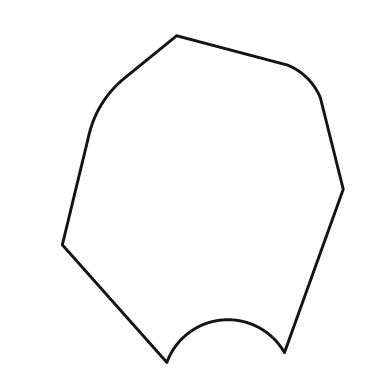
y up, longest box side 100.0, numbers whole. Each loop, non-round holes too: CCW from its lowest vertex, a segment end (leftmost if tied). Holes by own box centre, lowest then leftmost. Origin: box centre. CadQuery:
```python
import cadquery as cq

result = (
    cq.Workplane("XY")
    .moveTo(-11.0, -50.0)
    .threePointArc((6.0, -37.0), (25.0, -47.0))
    .lineTo(43.0, 3.0)
    .lineTo(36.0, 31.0)
    .threePointArc((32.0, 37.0), (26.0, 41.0))
    .lineTo(-8.0, 50.0)
    .lineTo(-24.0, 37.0)
    .threePointArc((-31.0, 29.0), (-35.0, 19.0))
    .lineTo(-43.0, -14.0)
    .close()
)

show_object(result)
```